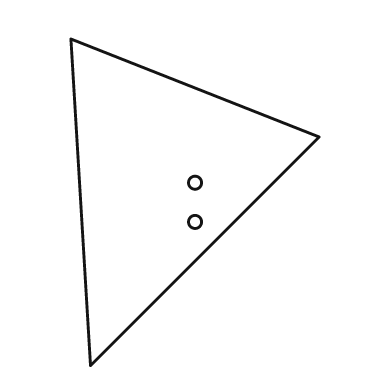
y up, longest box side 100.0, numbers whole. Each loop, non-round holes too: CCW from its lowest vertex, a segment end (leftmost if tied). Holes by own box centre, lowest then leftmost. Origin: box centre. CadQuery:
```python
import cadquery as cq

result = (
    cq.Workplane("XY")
    .moveTo(-32.0, -50.0)
    .lineTo(38.0, 20.0)
    .lineTo(-38.0, 50.0)
    .close()
    .moveTo(0.0, -6.0)
    .circle(2.0)
    .moveTo(0.0, 6.0)
    .circle(2.0)
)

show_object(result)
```